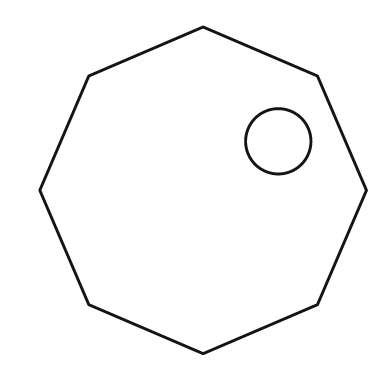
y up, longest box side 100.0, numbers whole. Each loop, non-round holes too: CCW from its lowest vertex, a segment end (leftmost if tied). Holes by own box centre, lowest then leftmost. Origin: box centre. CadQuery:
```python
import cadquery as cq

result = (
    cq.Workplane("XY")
    .moveTo(0.0, -50.0)
    .lineTo(35.0, -35.0)
    .lineTo(50.0, 0.0)
    .lineTo(35.0, 35.0)
    .lineTo(0.0, 50.0)
    .lineTo(-35.0, 35.0)
    .lineTo(-50.0, 0.0)
    .lineTo(-35.0, -35.0)
    .close()
    .moveTo(23.0, 15.0)
    .circle(10.0)
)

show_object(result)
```